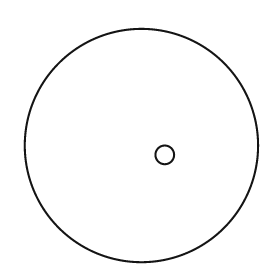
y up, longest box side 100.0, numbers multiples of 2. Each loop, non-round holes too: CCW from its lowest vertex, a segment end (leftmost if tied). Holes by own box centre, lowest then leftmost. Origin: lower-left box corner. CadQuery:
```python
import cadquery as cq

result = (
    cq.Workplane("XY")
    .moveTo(50.0, 50.0)
    .circle(50.0)
    .moveTo(60.0, 46.0)
    .circle(4.0)
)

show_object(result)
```